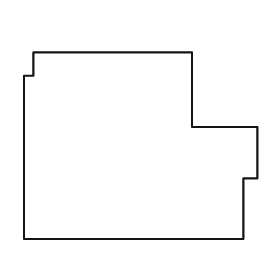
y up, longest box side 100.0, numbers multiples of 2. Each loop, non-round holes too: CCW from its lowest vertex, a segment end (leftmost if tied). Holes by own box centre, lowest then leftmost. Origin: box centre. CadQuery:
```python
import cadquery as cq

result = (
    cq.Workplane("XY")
    .moveTo(-50.0, -40.0)
    .lineTo(44.0, -40.0)
    .lineTo(44.0, -14.0)
    .lineTo(50.0, -14.0)
    .lineTo(50.0, 8.0)
    .lineTo(22.0, 8.0)
    .lineTo(22.0, 40.0)
    .lineTo(-46.0, 40.0)
    .lineTo(-46.0, 30.0)
    .lineTo(-50.0, 30.0)
    .close()
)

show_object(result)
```